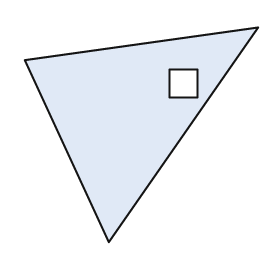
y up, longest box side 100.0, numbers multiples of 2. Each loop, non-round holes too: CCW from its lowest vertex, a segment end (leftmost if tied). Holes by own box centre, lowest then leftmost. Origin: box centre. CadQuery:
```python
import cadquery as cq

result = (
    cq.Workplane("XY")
    .moveTo(-14.0, -46.0)
    .lineTo(50.0, 46.0)
    .lineTo(-50.0, 32.0)
    .close()
    .moveTo(12.0, 16.0)
    .lineTo(24.0, 16.0)
    .lineTo(24.0, 28.0)
    .lineTo(12.0, 28.0)
    .close()
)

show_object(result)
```